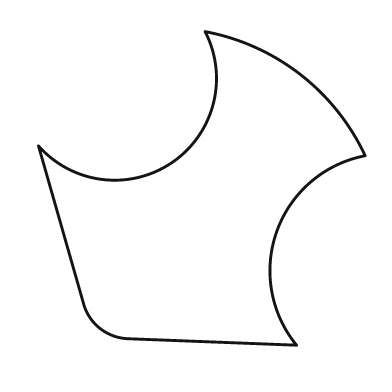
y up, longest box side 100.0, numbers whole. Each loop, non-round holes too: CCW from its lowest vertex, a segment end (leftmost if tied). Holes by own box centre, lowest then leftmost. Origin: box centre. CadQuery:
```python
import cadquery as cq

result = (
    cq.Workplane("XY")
    .moveTo(29.0, -48.0)
    .threePointArc((23.0, -13.0), (50.0, 10.0))
    .threePointArc((30.0, 35.0), (1.0, 48.0))
    .threePointArc((-9.0, 8.0), (-50.0, 13.0))
    .lineTo(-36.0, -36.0)
    .threePointArc((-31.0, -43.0), (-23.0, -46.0))
    .close()
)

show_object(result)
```